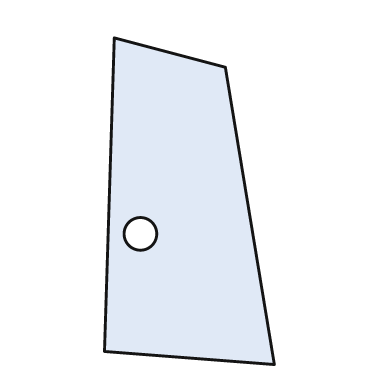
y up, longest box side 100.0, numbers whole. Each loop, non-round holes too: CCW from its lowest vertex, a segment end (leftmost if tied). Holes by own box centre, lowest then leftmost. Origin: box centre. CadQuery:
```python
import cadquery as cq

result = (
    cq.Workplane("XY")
    .moveTo(26.0, -50.0)
    .lineTo(11.0, 41.0)
    .lineTo(-23.0, 50.0)
    .lineTo(-26.0, -46.0)
    .close()
    .moveTo(-15.0, -10.0)
    .circle(5.0)
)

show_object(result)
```